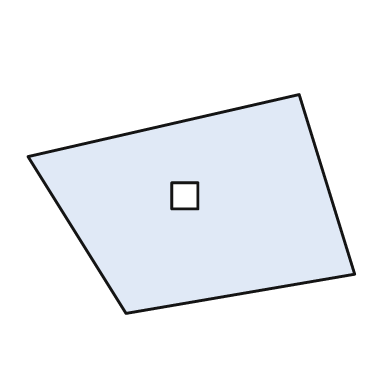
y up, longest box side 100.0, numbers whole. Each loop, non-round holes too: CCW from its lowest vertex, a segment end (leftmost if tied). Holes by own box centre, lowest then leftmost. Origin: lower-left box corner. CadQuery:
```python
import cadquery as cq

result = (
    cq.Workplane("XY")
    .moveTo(30.0, 0.0)
    .lineTo(100.0, 12.0)
    .lineTo(83.0, 67.0)
    .lineTo(0.0, 48.0)
    .close()
    .moveTo(44.0, 32.0)
    .lineTo(52.0, 32.0)
    .lineTo(52.0, 40.0)
    .lineTo(44.0, 40.0)
    .close()
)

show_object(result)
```